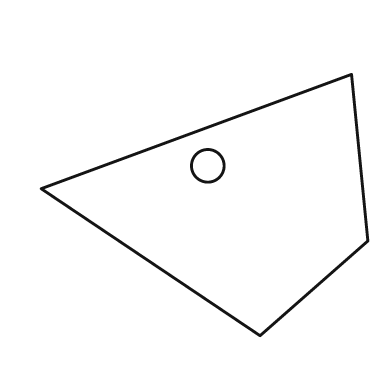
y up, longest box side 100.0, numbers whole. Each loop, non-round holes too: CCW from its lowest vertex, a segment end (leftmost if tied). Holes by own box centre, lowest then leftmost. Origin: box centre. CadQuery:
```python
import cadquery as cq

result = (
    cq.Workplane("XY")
    .moveTo(17.0, -40.0)
    .lineTo(50.0, -11.0)
    .lineTo(45.0, 40.0)
    .lineTo(-50.0, 5.0)
    .close()
    .moveTo(1.0, 12.0)
    .circle(5.0)
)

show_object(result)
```